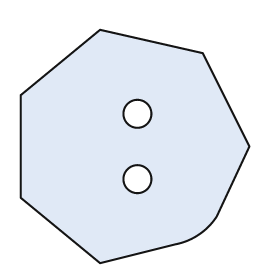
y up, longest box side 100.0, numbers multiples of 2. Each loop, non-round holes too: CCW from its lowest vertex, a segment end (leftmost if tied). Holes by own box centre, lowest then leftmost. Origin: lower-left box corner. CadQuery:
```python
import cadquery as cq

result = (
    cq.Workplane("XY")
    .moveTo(34.0, 0.0)
    .lineTo(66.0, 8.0)
    .threePointArc((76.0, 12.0), (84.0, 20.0))
    .lineTo(98.0, 50.0)
    .lineTo(78.0, 90.0)
    .lineTo(34.0, 100.0)
    .lineTo(0.0, 72.0)
    .lineTo(0.0, 28.0)
    .close()
    .moveTo(50.0, 36.0)
    .circle(6.0)
    .moveTo(50.0, 64.0)
    .circle(6.0)
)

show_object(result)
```